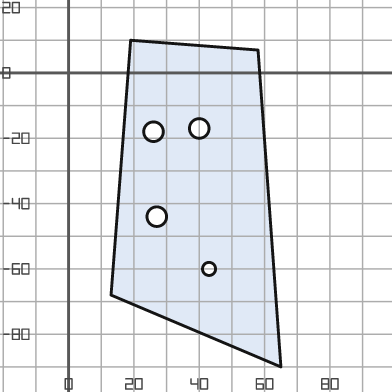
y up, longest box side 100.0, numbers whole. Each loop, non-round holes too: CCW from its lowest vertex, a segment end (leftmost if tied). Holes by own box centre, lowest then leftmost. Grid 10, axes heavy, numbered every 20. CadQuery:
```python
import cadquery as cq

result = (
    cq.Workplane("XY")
    .moveTo(65.0, -90.0)
    .lineTo(58.0, 7.0)
    .lineTo(19.0, 10.0)
    .lineTo(13.0, -68.0)
    .close()
    .moveTo(43.0, -60.0)
    .circle(2.0)
    .moveTo(27.0, -44.0)
    .circle(3.0)
    .moveTo(26.0, -18.0)
    .circle(3.0)
    .moveTo(40.0, -17.0)
    .circle(3.0)
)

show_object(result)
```